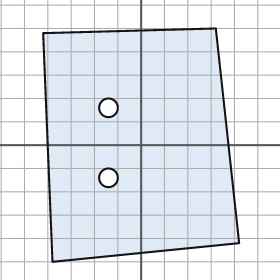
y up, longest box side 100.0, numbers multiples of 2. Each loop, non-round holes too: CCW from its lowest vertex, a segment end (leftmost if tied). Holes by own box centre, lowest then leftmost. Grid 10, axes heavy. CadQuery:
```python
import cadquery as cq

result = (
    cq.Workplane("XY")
    .moveTo(-38.0, -50.0)
    .lineTo(42.0, -42.0)
    .lineTo(32.0, 50.0)
    .lineTo(-42.0, 48.0)
    .close()
    .moveTo(-14.0, -14.0)
    .circle(4.0)
    .moveTo(-14.0, 16.0)
    .circle(4.0)
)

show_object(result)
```